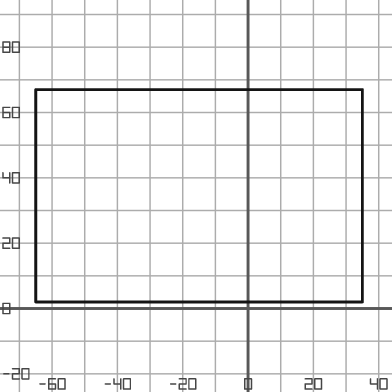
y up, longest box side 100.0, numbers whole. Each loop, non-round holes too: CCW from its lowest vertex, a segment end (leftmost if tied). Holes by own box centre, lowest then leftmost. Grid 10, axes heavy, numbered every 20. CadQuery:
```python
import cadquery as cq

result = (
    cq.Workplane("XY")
    .moveTo(-65.0, 2.0)
    .lineTo(35.0, 2.0)
    .lineTo(35.0, 67.0)
    .lineTo(-65.0, 67.0)
    .close()
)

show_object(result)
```